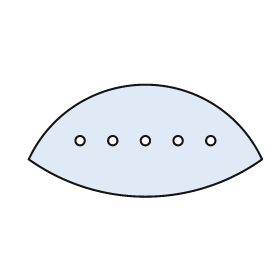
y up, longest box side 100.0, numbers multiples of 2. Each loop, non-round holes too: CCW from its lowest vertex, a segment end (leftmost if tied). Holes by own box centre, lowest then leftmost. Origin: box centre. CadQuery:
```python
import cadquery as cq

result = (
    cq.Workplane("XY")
    .moveTo(-50.0, -8.0)
    .threePointArc((0.0, -24.0), (50.0, -8.0))
    .threePointArc((0.0, 24.0), (-50.0, -8.0))
    .close()
    .moveTo(-28.0, 0.0)
    .circle(2.0)
    .moveTo(-14.0, 0.0)
    .circle(2.0)
    .moveTo(0.0, 0.0)
    .circle(2.0)
    .moveTo(14.0, 0.0)
    .circle(2.0)
    .moveTo(28.0, 0.0)
    .circle(2.0)
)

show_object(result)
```